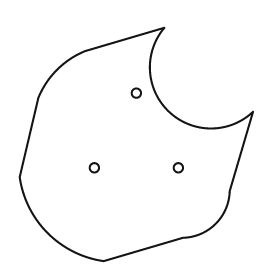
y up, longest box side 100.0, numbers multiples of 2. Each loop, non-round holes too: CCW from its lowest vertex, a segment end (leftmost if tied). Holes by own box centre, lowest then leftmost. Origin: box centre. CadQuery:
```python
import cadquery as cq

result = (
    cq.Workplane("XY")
    .moveTo(-14.0, -50.0)
    .lineTo(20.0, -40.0)
    .threePointArc((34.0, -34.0), (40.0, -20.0))
    .lineTo(50.0, 14.0)
    .threePointArc((14.0, 14.0), (12.0, 50.0))
    .lineTo(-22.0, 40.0)
    .threePointArc((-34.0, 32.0), (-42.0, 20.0))
    .lineTo(-50.0, -14.0)
    .threePointArc((-38.0, -38.0), (-14.0, -50.0))
    .close()
    .moveTo(-18.0, -10.0)
    .circle(2.0)
    .moveTo(18.0, -10.0)
    .circle(2.0)
    .moveTo(0.0, 22.0)
    .circle(2.0)
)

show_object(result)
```